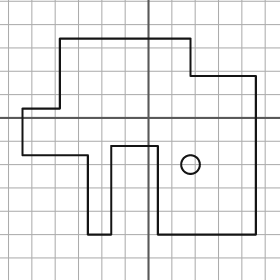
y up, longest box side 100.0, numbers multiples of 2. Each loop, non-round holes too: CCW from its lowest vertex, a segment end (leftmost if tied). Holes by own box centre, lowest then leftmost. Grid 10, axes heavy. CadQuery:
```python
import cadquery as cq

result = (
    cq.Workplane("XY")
    .moveTo(-26.0, -50.0)
    .lineTo(-16.0, -50.0)
    .lineTo(-16.0, -12.0)
    .lineTo(4.0, -12.0)
    .lineTo(4.0, -50.0)
    .lineTo(46.0, -50.0)
    .lineTo(46.0, 18.0)
    .lineTo(18.0, 18.0)
    .lineTo(18.0, 34.0)
    .lineTo(-38.0, 34.0)
    .lineTo(-38.0, 4.0)
    .lineTo(-54.0, 4.0)
    .lineTo(-54.0, -16.0)
    .lineTo(-26.0, -16.0)
    .close()
    .moveTo(18.0, -20.0)
    .circle(4.0)
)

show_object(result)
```